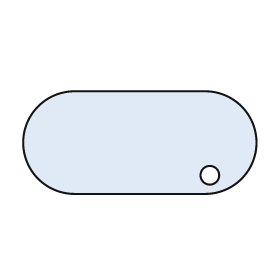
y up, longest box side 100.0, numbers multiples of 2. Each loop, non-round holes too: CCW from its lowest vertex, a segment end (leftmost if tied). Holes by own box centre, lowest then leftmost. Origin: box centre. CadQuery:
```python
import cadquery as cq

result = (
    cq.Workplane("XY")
    .moveTo(-28.0, -22.0)
    .lineTo(28.0, -22.0)
    .threePointArc((50.0, 0.0), (28.0, 22.0))
    .lineTo(-28.0, 22.0)
    .threePointArc((-50.0, 0.0), (-28.0, -22.0))
    .close()
    .moveTo(30.0, -14.0)
    .circle(4.0)
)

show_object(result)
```